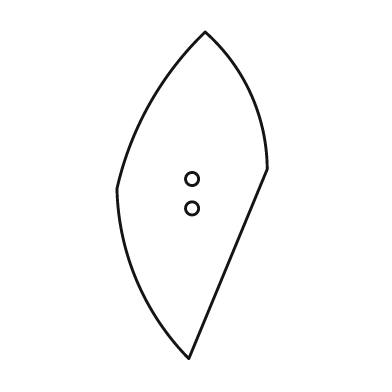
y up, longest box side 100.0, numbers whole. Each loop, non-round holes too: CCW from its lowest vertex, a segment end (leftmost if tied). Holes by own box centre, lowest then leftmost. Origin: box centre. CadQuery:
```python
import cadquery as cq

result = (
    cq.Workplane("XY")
    .moveTo(-1.0, -50.0)
    .lineTo(23.0, 8.0)
    .threePointArc((18.0, 31.0), (4.0, 50.0))
    .threePointArc((-13.0, 28.0), (-23.0, 2.0))
    .threePointArc((-17.0, -26.0), (-1.0, -50.0))
    .close()
    .moveTo(0.0, -4.0)
    .circle(2.0)
    .moveTo(0.0, 5.0)
    .circle(2.0)
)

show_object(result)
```